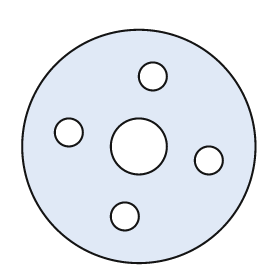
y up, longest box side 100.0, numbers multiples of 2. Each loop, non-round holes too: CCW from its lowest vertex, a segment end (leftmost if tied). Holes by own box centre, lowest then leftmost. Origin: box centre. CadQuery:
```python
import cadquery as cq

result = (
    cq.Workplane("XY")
    .moveTo(0.0, 0.0)
    .circle(50.0)
    .moveTo(-6.0, -30.0)
    .circle(6.0)
    .moveTo(30.0, -6.0)
    .circle(6.0)
    .moveTo(0.0, 0.0)
    .circle(12.0)
    .moveTo(-30.0, 6.0)
    .circle(6.0)
    .moveTo(6.0, 30.0)
    .circle(6.0)
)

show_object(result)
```